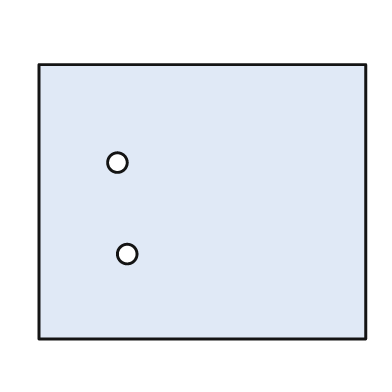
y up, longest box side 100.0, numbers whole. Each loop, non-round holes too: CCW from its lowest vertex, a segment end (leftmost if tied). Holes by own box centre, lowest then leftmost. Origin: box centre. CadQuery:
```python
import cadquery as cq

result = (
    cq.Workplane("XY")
    .moveTo(-50.0, -42.0)
    .lineTo(50.0, -42.0)
    .lineTo(50.0, 42.0)
    .lineTo(-50.0, 42.0)
    .close()
    .moveTo(-23.0, -16.0)
    .circle(3.0)
    .moveTo(-26.0, 12.0)
    .circle(3.0)
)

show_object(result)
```